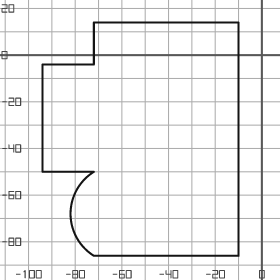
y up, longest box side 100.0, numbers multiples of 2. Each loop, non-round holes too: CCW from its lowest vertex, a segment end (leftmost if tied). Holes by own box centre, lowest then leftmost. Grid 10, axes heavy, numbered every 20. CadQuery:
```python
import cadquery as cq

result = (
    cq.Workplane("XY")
    .moveTo(-72.0, -86.0)
    .lineTo(-10.0, -86.0)
    .lineTo(-10.0, 14.0)
    .lineTo(-72.0, 14.0)
    .lineTo(-72.0, -4.0)
    .lineTo(-94.0, -4.0)
    .lineTo(-94.0, -50.0)
    .lineTo(-72.0, -50.0)
    .threePointArc((-82.0, -68.0), (-72.0, -86.0))
    .close()
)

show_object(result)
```